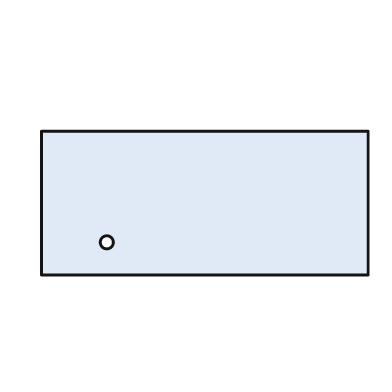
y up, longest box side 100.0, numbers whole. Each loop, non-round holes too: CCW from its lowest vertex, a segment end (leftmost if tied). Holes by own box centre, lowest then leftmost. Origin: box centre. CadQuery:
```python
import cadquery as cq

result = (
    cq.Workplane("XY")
    .moveTo(-50.0, -22.0)
    .lineTo(50.0, -22.0)
    .lineTo(50.0, 22.0)
    .lineTo(-50.0, 22.0)
    .close()
    .moveTo(-30.0, -12.0)
    .circle(2.0)
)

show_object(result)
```